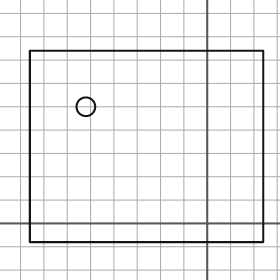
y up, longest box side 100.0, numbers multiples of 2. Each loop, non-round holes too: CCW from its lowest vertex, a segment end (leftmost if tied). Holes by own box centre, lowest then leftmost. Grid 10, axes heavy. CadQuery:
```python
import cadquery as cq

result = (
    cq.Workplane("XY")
    .moveTo(-76.0, -8.0)
    .lineTo(24.0, -8.0)
    .lineTo(24.0, 74.0)
    .lineTo(-76.0, 74.0)
    .close()
    .moveTo(-52.0, 50.0)
    .circle(4.0)
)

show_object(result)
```